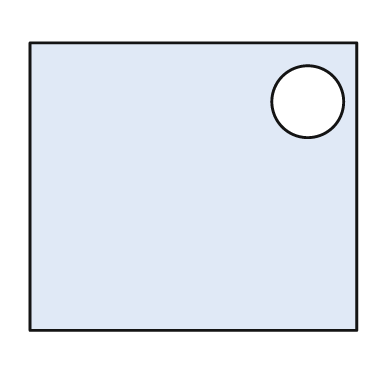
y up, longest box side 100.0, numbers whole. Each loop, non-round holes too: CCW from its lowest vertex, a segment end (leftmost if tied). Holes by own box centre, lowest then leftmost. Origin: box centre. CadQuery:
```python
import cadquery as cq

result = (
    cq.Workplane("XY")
    .moveTo(-50.0, -44.0)
    .lineTo(50.0, -44.0)
    .lineTo(50.0, 44.0)
    .lineTo(-50.0, 44.0)
    .close()
    .moveTo(35.0, 26.0)
    .circle(11.0)
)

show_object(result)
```